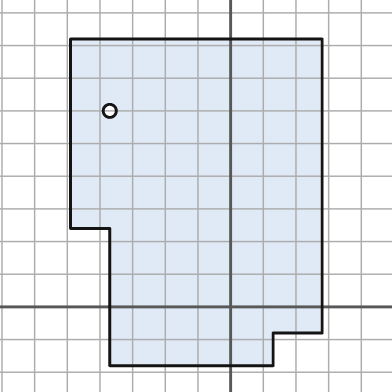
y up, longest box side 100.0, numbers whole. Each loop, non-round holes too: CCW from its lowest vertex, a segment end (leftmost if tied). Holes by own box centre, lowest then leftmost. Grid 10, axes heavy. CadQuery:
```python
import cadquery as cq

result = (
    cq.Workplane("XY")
    .moveTo(-37.0, -18.0)
    .lineTo(13.0, -18.0)
    .lineTo(13.0, -8.0)
    .lineTo(28.0, -8.0)
    .lineTo(28.0, 82.0)
    .lineTo(-49.0, 82.0)
    .lineTo(-49.0, 24.0)
    .lineTo(-37.0, 24.0)
    .close()
    .moveTo(-37.0, 60.0)
    .circle(2.0)
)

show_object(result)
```